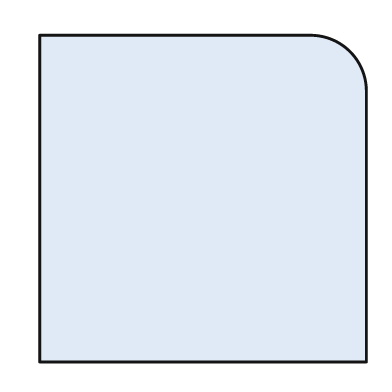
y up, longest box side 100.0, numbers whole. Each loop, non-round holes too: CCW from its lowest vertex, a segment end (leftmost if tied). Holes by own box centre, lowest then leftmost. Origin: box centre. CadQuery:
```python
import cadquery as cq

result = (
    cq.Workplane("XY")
    .moveTo(-50.0, -50.0)
    .lineTo(50.0, -50.0)
    .lineTo(50.0, 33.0)
    .threePointArc((45.0, 45.0), (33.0, 50.0))
    .lineTo(-50.0, 50.0)
    .close()
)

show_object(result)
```